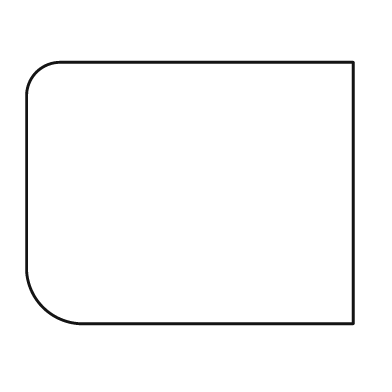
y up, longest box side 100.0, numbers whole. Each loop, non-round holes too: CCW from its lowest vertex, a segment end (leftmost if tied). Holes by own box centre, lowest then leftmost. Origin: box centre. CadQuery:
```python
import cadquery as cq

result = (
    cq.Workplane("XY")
    .moveTo(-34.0, -40.0)
    .lineTo(50.0, -40.0)
    .lineTo(50.0, 40.0)
    .lineTo(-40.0, 40.0)
    .threePointArc((-47.0, 37.0), (-50.0, 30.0))
    .lineTo(-50.0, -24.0)
    .threePointArc((-45.0, -35.0), (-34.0, -40.0))
    .close()
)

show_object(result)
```